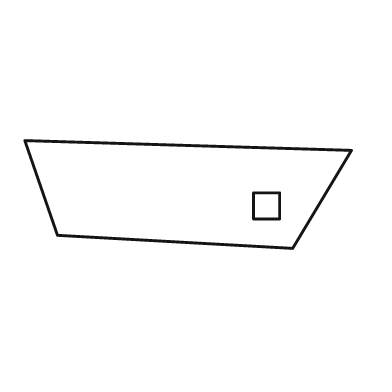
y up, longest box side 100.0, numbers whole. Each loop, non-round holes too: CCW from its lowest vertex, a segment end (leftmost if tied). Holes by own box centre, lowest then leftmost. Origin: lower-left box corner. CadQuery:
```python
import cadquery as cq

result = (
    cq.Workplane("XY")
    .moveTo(82.0, 0.0)
    .lineTo(100.0, 30.0)
    .lineTo(0.0, 33.0)
    .lineTo(10.0, 4.0)
    .close()
    .moveTo(70.0, 9.0)
    .lineTo(78.0, 9.0)
    .lineTo(78.0, 17.0)
    .lineTo(70.0, 17.0)
    .close()
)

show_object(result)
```